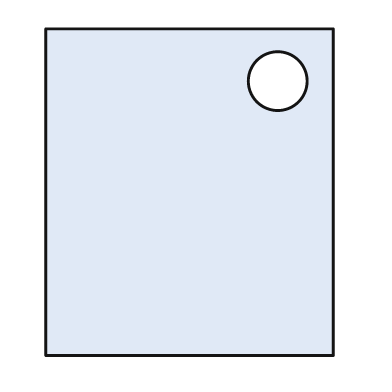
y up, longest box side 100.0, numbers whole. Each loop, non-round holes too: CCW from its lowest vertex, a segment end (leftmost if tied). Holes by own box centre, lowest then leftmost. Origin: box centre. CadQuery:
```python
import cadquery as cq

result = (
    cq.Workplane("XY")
    .moveTo(-44.0, -50.0)
    .lineTo(44.0, -50.0)
    .lineTo(44.0, 50.0)
    .lineTo(-44.0, 50.0)
    .close()
    .moveTo(27.0, 34.0)
    .circle(9.0)
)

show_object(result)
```